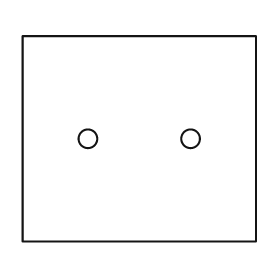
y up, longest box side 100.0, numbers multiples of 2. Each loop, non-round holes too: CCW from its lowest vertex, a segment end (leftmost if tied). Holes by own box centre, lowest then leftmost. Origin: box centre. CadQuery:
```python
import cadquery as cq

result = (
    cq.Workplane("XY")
    .moveTo(-50.0, -44.0)
    .lineTo(50.0, -44.0)
    .lineTo(50.0, 44.0)
    .lineTo(-50.0, 44.0)
    .close()
    .moveTo(-22.0, 0.0)
    .circle(4.0)
    .moveTo(22.0, 0.0)
    .circle(4.0)
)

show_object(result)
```